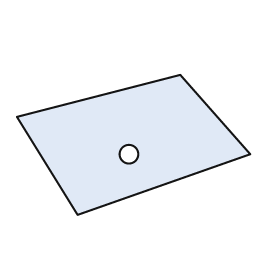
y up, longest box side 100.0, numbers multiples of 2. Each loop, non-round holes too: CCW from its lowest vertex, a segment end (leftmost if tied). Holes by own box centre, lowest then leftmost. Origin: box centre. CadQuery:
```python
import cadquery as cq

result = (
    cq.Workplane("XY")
    .moveTo(-24.0, -30.0)
    .lineTo(50.0, -4.0)
    .lineTo(20.0, 30.0)
    .lineTo(-50.0, 12.0)
    .close()
    .moveTo(-2.0, -4.0)
    .circle(4.0)
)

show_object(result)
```